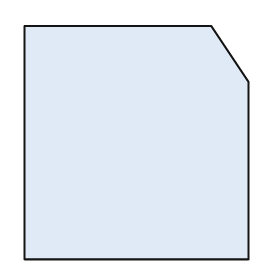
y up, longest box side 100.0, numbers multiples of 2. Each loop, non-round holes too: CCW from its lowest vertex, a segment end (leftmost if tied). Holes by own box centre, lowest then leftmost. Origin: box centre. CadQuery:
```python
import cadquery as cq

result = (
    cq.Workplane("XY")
    .moveTo(-48.0, -50.0)
    .lineTo(48.0, -50.0)
    .lineTo(48.0, 26.0)
    .lineTo(32.0, 50.0)
    .lineTo(-48.0, 50.0)
    .close()
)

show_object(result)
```